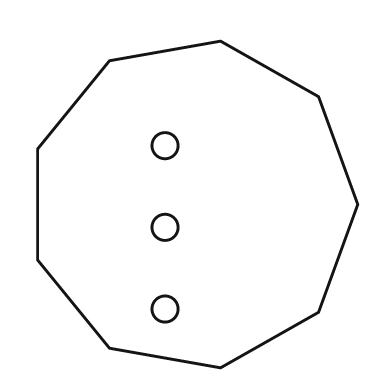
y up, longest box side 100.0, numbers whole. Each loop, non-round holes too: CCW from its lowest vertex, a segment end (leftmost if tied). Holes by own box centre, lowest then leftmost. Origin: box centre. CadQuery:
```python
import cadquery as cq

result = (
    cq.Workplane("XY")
    .moveTo(7.0, -50.0)
    .lineTo(37.0, -33.0)
    .lineTo(49.0, 0.0)
    .lineTo(37.0, 33.0)
    .lineTo(7.0, 50.0)
    .lineTo(-27.0, 44.0)
    .lineTo(-49.0, 17.0)
    .lineTo(-49.0, -17.0)
    .lineTo(-27.0, -44.0)
    .close()
    .moveTo(-10.0, -32.0)
    .circle(4.0)
    .moveTo(-10.0, -7.0)
    .circle(4.0)
    .moveTo(-10.0, 18.0)
    .circle(4.0)
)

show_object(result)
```